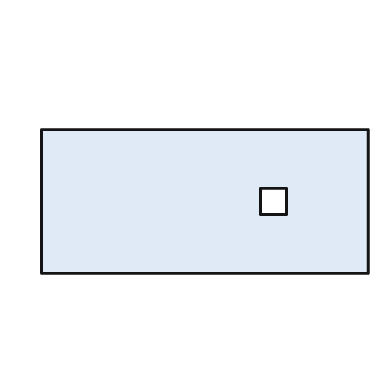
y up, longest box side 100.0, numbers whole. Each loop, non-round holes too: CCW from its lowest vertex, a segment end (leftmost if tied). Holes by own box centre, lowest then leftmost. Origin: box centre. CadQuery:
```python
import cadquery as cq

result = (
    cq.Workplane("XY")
    .moveTo(-50.0, -22.0)
    .lineTo(50.0, -22.0)
    .lineTo(50.0, 22.0)
    .lineTo(-50.0, 22.0)
    .close()
    .moveTo(17.0, -4.0)
    .lineTo(25.0, -4.0)
    .lineTo(25.0, 4.0)
    .lineTo(17.0, 4.0)
    .close()
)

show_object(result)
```